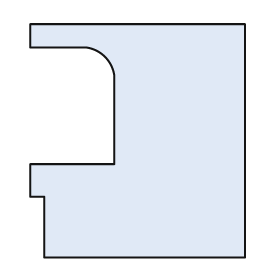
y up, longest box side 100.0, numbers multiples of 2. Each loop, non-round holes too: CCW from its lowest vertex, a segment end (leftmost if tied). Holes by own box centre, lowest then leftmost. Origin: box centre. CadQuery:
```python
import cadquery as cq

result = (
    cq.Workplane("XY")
    .moveTo(-40.0, -50.0)
    .lineTo(46.0, -50.0)
    .lineTo(46.0, 50.0)
    .lineTo(-46.0, 50.0)
    .lineTo(-46.0, 40.0)
    .lineTo(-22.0, 40.0)
    .threePointArc((-14.0, 36.0), (-10.0, 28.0))
    .lineTo(-10.0, -10.0)
    .lineTo(-46.0, -10.0)
    .lineTo(-46.0, -24.0)
    .lineTo(-40.0, -24.0)
    .close()
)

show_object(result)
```